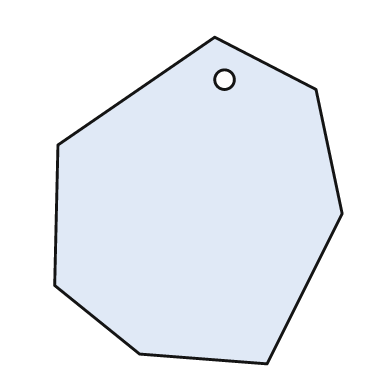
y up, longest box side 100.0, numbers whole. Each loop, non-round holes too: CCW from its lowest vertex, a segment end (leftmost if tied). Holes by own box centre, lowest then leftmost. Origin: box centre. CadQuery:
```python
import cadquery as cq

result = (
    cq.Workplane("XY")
    .moveTo(21.0, -50.0)
    .lineTo(44.0, -4.0)
    .lineTo(36.0, 34.0)
    .lineTo(5.0, 50.0)
    .lineTo(-43.0, 17.0)
    .lineTo(-44.0, -26.0)
    .lineTo(-18.0, -47.0)
    .close()
    .moveTo(8.0, 37.0)
    .circle(3.0)
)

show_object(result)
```